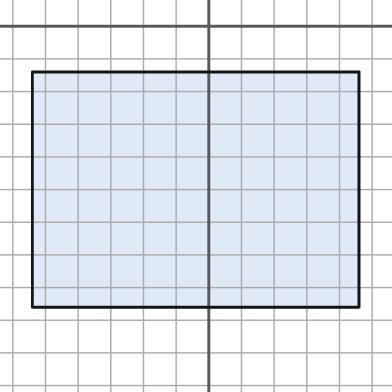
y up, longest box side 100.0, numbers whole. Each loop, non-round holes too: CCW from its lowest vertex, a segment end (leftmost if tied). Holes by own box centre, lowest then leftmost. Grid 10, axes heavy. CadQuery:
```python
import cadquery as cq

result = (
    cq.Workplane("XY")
    .moveTo(-54.0, -86.0)
    .lineTo(46.0, -86.0)
    .lineTo(46.0, -14.0)
    .lineTo(-54.0, -14.0)
    .close()
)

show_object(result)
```